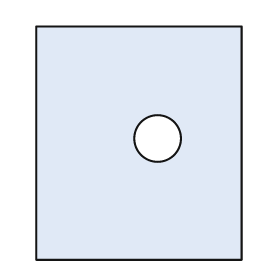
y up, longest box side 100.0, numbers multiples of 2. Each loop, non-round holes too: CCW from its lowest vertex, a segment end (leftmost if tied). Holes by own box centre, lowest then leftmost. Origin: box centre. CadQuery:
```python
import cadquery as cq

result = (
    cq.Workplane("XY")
    .moveTo(-44.0, -50.0)
    .lineTo(44.0, -50.0)
    .lineTo(44.0, 50.0)
    .lineTo(-44.0, 50.0)
    .close()
    .moveTo(8.0, 2.0)
    .circle(10.0)
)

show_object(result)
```